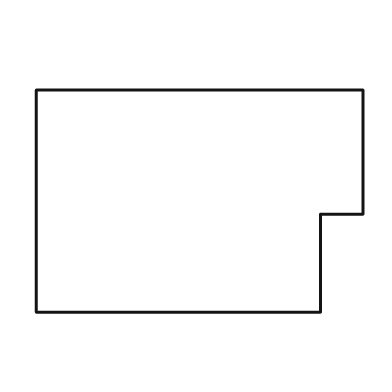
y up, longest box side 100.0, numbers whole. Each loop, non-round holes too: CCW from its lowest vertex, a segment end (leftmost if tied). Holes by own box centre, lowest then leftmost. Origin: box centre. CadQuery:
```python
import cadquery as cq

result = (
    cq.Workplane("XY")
    .moveTo(-50.0, -34.0)
    .lineTo(37.0, -34.0)
    .lineTo(37.0, -4.0)
    .lineTo(50.0, -4.0)
    .lineTo(50.0, 34.0)
    .lineTo(-50.0, 34.0)
    .close()
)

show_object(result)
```